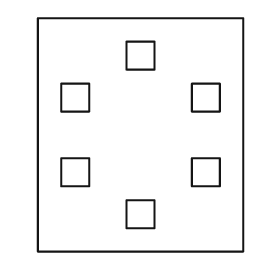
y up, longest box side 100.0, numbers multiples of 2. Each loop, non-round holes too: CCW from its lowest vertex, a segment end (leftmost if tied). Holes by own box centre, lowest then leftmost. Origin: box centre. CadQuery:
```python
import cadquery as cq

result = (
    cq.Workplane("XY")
    .moveTo(-44.0, -50.0)
    .lineTo(44.0, -50.0)
    .lineTo(44.0, 50.0)
    .lineTo(-44.0, 50.0)
    .close()
    .moveTo(-6.0, -40.0)
    .lineTo(6.0, -40.0)
    .lineTo(6.0, -28.0)
    .lineTo(-6.0, -28.0)
    .close()
    .moveTo(-34.0, -22.0)
    .lineTo(-22.0, -22.0)
    .lineTo(-22.0, -10.0)
    .lineTo(-34.0, -10.0)
    .close()
    .moveTo(22.0, -22.0)
    .lineTo(34.0, -22.0)
    .lineTo(34.0, -10.0)
    .lineTo(22.0, -10.0)
    .close()
    .moveTo(-34.0, 10.0)
    .lineTo(-22.0, 10.0)
    .lineTo(-22.0, 22.0)
    .lineTo(-34.0, 22.0)
    .close()
    .moveTo(22.0, 10.0)
    .lineTo(34.0, 10.0)
    .lineTo(34.0, 22.0)
    .lineTo(22.0, 22.0)
    .close()
    .moveTo(-6.0, 28.0)
    .lineTo(6.0, 28.0)
    .lineTo(6.0, 40.0)
    .lineTo(-6.0, 40.0)
    .close()
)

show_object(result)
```